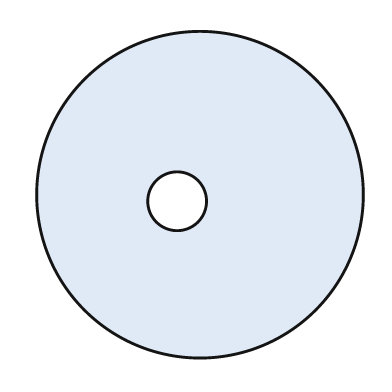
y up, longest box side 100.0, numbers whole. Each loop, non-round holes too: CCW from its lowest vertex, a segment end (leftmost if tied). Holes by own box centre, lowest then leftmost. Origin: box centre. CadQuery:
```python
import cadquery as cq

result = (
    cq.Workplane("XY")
    .moveTo(0.0, 0.0)
    .circle(50.0)
    .moveTo(-7.0, -2.0)
    .circle(9.0)
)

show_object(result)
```